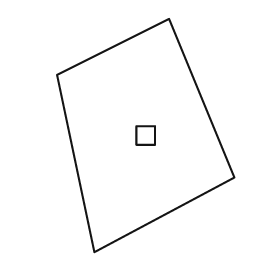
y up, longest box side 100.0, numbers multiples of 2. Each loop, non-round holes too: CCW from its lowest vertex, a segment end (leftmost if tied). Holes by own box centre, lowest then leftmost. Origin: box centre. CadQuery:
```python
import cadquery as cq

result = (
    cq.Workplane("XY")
    .moveTo(-22.0, -50.0)
    .lineTo(38.0, -18.0)
    .lineTo(10.0, 50.0)
    .lineTo(-38.0, 26.0)
    .close()
    .moveTo(-4.0, -4.0)
    .lineTo(4.0, -4.0)
    .lineTo(4.0, 4.0)
    .lineTo(-4.0, 4.0)
    .close()
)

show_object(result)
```